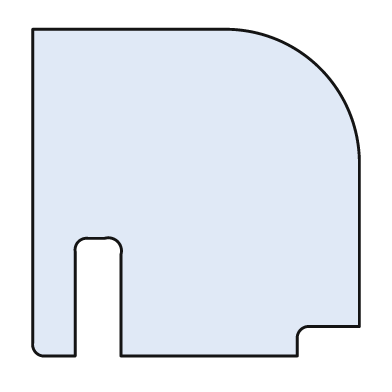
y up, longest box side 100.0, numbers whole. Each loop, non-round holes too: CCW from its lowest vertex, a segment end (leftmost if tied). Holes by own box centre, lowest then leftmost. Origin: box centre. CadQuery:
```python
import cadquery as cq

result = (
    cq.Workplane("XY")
    .moveTo(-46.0, -50.0)
    .lineTo(-37.0, -50.0)
    .lineTo(-37.0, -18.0)
    .threePointArc((-36.0, -15.0), (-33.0, -14.0))
    .lineTo(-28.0, -14.0)
    .threePointArc((-24.0, -15.0), (-23.0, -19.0))
    .lineTo(-23.0, -50.0)
    .lineTo(31.0, -50.0)
    .lineTo(31.0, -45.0)
    .threePointArc((32.0, -42.0), (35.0, -41.0))
    .lineTo(50.0, -41.0)
    .lineTo(50.0, 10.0)
    .threePointArc((38.0, 38.0), (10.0, 50.0))
    .lineTo(-50.0, 50.0)
    .lineTo(-50.0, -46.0)
    .threePointArc((-49.0, -49.0), (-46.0, -50.0))
    .close()
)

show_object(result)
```